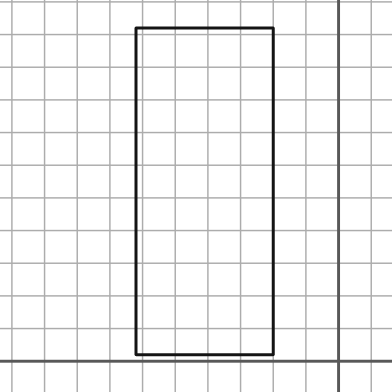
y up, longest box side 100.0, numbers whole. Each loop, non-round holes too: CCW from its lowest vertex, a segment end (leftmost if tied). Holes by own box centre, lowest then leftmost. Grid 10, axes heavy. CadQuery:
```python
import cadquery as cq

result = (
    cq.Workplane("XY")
    .moveTo(-62.0, 2.0)
    .lineTo(-20.0, 2.0)
    .lineTo(-20.0, 102.0)
    .lineTo(-62.0, 102.0)
    .close()
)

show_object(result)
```